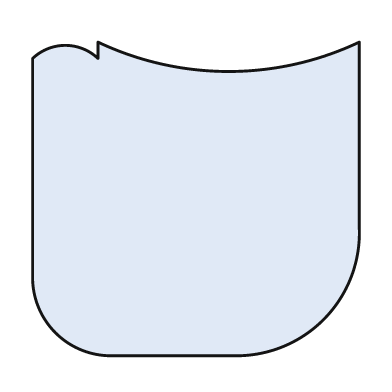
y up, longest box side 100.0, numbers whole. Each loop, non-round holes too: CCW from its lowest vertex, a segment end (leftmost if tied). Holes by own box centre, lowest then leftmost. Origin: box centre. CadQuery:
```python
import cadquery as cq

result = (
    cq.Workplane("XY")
    .moveTo(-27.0, -48.0)
    .lineTo(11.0, -48.0)
    .threePointArc((39.0, -37.0), (50.0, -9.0))
    .lineTo(50.0, 48.0)
    .threePointArc((10.0, 39.0), (-30.0, 48.0))
    .lineTo(-30.0, 43.0)
    .threePointArc((-40.0, 47.0), (-50.0, 43.0))
    .lineTo(-50.0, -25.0)
    .threePointArc((-43.0, -41.0), (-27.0, -48.0))
    .close()
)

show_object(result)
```